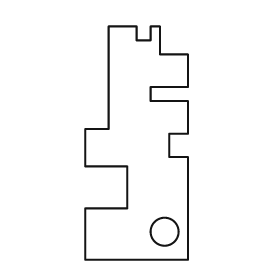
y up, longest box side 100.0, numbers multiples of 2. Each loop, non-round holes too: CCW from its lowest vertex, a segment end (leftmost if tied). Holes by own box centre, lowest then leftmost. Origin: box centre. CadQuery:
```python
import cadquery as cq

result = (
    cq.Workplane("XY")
    .moveTo(-22.0, -50.0)
    .lineTo(22.0, -50.0)
    .lineTo(22.0, -6.0)
    .lineTo(14.0, -6.0)
    .lineTo(14.0, 4.0)
    .lineTo(22.0, 4.0)
    .lineTo(22.0, 18.0)
    .lineTo(6.0, 18.0)
    .lineTo(6.0, 24.0)
    .lineTo(22.0, 24.0)
    .lineTo(22.0, 38.0)
    .lineTo(10.0, 38.0)
    .lineTo(10.0, 50.0)
    .lineTo(6.0, 50.0)
    .lineTo(6.0, 44.0)
    .lineTo(0.0, 44.0)
    .lineTo(0.0, 50.0)
    .lineTo(-12.0, 50.0)
    .lineTo(-12.0, 6.0)
    .lineTo(-22.0, 6.0)
    .lineTo(-22.0, -10.0)
    .lineTo(-4.0, -10.0)
    .lineTo(-4.0, -28.0)
    .lineTo(-22.0, -28.0)
    .close()
    .moveTo(12.0, -38.0)
    .circle(6.0)
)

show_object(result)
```